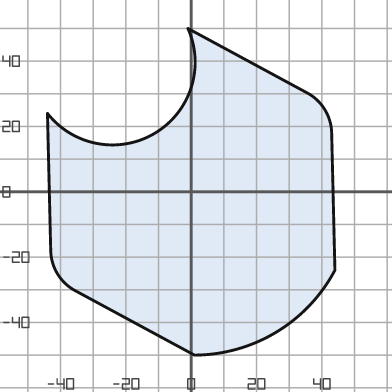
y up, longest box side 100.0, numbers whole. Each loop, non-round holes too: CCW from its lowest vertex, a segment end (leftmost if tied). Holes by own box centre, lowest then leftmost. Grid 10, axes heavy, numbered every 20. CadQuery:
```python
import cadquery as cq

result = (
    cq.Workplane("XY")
    .moveTo(1.0, -50.0)
    .threePointArc((26.0, -43.0), (44.0, -24.0))
    .lineTo(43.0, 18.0)
    .threePointArc((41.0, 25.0), (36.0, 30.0))
    .lineTo(-1.0, 50.0)
    .threePointArc((-11.0, 18.0), (-44.0, 24.0))
    .lineTo(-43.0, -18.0)
    .threePointArc((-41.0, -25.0), (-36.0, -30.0))
    .close()
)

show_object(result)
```